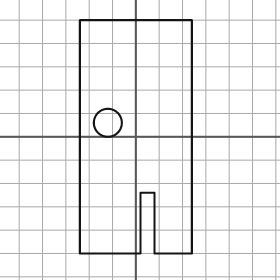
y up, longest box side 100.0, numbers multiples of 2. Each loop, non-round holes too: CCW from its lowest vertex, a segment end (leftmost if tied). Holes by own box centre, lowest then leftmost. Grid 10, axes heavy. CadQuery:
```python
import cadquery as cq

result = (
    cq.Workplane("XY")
    .moveTo(-24.0, -50.0)
    .lineTo(2.0, -50.0)
    .lineTo(2.0, -24.0)
    .lineTo(8.0, -24.0)
    .lineTo(8.0, -50.0)
    .lineTo(24.0, -50.0)
    .lineTo(24.0, 50.0)
    .lineTo(-24.0, 50.0)
    .close()
    .moveTo(-12.0, 6.0)
    .circle(6.0)
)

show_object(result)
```